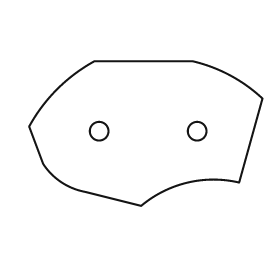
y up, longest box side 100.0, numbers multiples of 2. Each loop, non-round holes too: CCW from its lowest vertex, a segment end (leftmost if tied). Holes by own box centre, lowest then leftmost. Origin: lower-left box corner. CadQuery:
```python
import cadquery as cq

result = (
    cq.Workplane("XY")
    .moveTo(48.0, 0.0)
    .threePointArc((68.0, 10.0), (90.0, 10.0))
    .lineTo(100.0, 46.0)
    .threePointArc((86.0, 56.0), (70.0, 62.0))
    .lineTo(28.0, 62.0)
    .threePointArc((12.0, 50.0), (0.0, 34.0))
    .lineTo(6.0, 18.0)
    .threePointArc((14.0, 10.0), (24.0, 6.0))
    .close()
    .moveTo(30.0, 32.0)
    .circle(4.0)
    .moveTo(72.0, 32.0)
    .circle(4.0)
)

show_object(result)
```